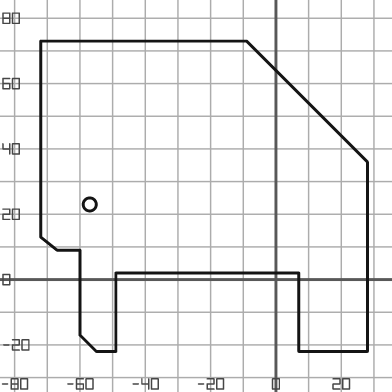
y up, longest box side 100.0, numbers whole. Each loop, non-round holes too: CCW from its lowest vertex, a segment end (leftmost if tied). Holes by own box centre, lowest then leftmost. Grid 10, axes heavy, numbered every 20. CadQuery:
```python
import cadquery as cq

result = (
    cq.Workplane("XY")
    .moveTo(-55.0, -22.0)
    .lineTo(-49.0, -22.0)
    .lineTo(-49.0, 2.0)
    .lineTo(7.0, 2.0)
    .lineTo(7.0, -22.0)
    .lineTo(28.0, -22.0)
    .lineTo(28.0, 36.0)
    .lineTo(-9.0, 73.0)
    .lineTo(-72.0, 73.0)
    .lineTo(-72.0, 13.0)
    .lineTo(-67.0, 9.0)
    .lineTo(-60.0, 9.0)
    .lineTo(-60.0, -17.0)
    .close()
    .moveTo(-57.0, 23.0)
    .circle(2.0)
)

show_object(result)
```